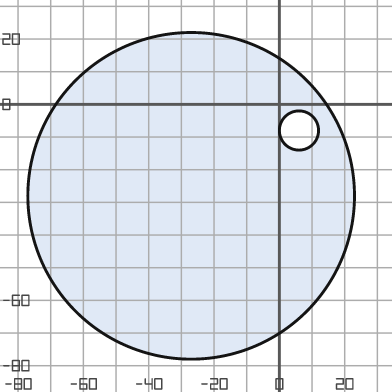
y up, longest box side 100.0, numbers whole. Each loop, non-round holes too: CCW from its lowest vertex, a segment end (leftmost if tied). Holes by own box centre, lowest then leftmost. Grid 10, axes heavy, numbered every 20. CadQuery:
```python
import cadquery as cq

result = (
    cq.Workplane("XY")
    .moveTo(-27.0, -28.0)
    .circle(50.0)
    .moveTo(6.0, -8.0)
    .circle(6.0)
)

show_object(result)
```